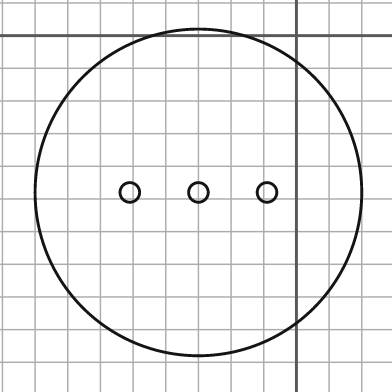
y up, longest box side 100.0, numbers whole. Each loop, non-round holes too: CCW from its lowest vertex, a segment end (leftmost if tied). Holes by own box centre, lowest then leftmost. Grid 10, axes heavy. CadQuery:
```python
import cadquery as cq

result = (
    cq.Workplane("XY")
    .moveTo(-30.0, -48.0)
    .circle(50.0)
    .moveTo(-51.0, -48.0)
    .circle(3.0)
    .moveTo(-30.0, -48.0)
    .circle(3.0)
    .moveTo(-9.0, -48.0)
    .circle(3.0)
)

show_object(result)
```